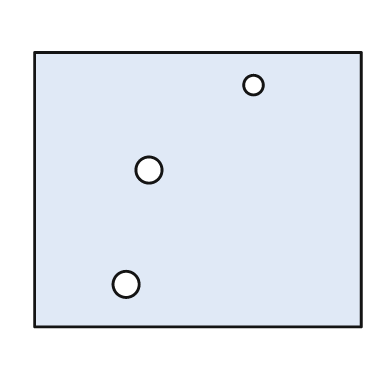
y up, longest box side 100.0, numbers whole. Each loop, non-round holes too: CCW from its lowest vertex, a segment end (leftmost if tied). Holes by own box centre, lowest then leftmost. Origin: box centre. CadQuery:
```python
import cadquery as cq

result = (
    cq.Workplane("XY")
    .moveTo(-50.0, -42.0)
    .lineTo(50.0, -42.0)
    .lineTo(50.0, 42.0)
    .lineTo(-50.0, 42.0)
    .close()
    .moveTo(-22.0, -29.0)
    .circle(4.0)
    .moveTo(-15.0, 6.0)
    .circle(4.0)
    .moveTo(17.0, 32.0)
    .circle(3.0)
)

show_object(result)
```